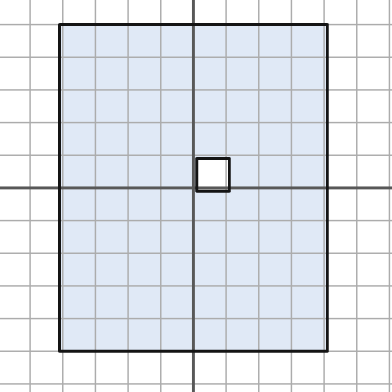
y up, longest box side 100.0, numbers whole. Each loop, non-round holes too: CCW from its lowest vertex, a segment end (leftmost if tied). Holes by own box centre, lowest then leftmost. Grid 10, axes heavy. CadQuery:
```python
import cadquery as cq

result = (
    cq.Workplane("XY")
    .moveTo(-41.0, -50.0)
    .lineTo(41.0, -50.0)
    .lineTo(41.0, 50.0)
    .lineTo(-41.0, 50.0)
    .close()
    .moveTo(1.0, -1.0)
    .lineTo(11.0, -1.0)
    .lineTo(11.0, 9.0)
    .lineTo(1.0, 9.0)
    .close()
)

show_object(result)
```